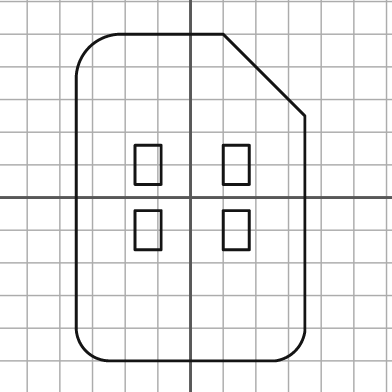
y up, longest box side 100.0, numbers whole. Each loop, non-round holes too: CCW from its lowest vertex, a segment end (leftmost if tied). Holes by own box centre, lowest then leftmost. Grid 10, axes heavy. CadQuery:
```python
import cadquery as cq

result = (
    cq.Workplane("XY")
    .moveTo(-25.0, -50.0)
    .lineTo(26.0, -50.0)
    .threePointArc((32.0, -47.0), (35.0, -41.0))
    .lineTo(35.0, 25.0)
    .lineTo(10.0, 50.0)
    .lineTo(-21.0, 50.0)
    .threePointArc((-31.0, 46.0), (-35.0, 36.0))
    .lineTo(-35.0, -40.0)
    .threePointArc((-32.0, -47.0), (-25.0, -50.0))
    .close()
    .moveTo(-17.0, -16.0)
    .lineTo(-9.0, -16.0)
    .lineTo(-9.0, -4.0)
    .lineTo(-17.0, -4.0)
    .close()
    .moveTo(10.0, -16.0)
    .lineTo(18.0, -16.0)
    .lineTo(18.0, -4.0)
    .lineTo(10.0, -4.0)
    .close()
    .moveTo(-17.0, 4.0)
    .lineTo(-9.0, 4.0)
    .lineTo(-9.0, 16.0)
    .lineTo(-17.0, 16.0)
    .close()
    .moveTo(10.0, 4.0)
    .lineTo(18.0, 4.0)
    .lineTo(18.0, 16.0)
    .lineTo(10.0, 16.0)
    .close()
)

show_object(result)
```